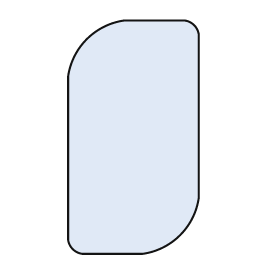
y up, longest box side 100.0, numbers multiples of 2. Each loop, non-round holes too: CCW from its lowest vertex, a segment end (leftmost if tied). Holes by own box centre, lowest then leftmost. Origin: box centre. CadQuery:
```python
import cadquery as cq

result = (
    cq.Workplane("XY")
    .moveTo(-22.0, -50.0)
    .lineTo(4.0, -50.0)
    .threePointArc((20.0, -42.0), (28.0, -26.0))
    .lineTo(28.0, 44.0)
    .threePointArc((26.0, 48.0), (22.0, 50.0))
    .lineTo(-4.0, 50.0)
    .threePointArc((-20.0, 42.0), (-28.0, 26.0))
    .lineTo(-28.0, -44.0)
    .threePointArc((-26.0, -48.0), (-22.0, -50.0))
    .close()
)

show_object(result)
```